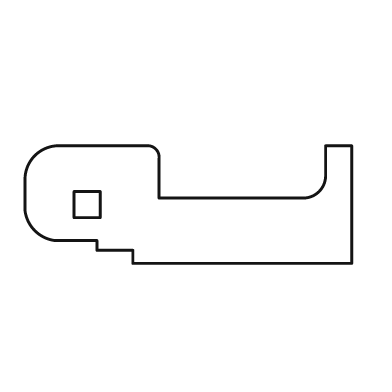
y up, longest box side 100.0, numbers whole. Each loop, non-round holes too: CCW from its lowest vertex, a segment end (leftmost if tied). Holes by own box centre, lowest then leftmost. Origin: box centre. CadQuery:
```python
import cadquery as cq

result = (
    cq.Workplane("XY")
    .moveTo(-17.0, -18.0)
    .lineTo(50.0, -18.0)
    .lineTo(50.0, 18.0)
    .lineTo(42.0, 18.0)
    .lineTo(42.0, 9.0)
    .threePointArc((40.0, 4.0), (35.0, 2.0))
    .lineTo(-9.0, 2.0)
    .lineTo(-9.0, 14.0)
    .threePointArc((-10.0, 17.0), (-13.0, 18.0))
    .lineTo(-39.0, 18.0)
    .threePointArc((-47.0, 15.0), (-50.0, 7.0))
    .lineTo(-50.0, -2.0)
    .threePointArc((-47.0, -8.0), (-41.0, -11.0))
    .lineTo(-28.0, -11.0)
    .lineTo(-28.0, -14.0)
    .lineTo(-17.0, -14.0)
    .close()
    .moveTo(-35.0, -4.0)
    .lineTo(-27.0, -4.0)
    .lineTo(-27.0, 4.0)
    .lineTo(-35.0, 4.0)
    .close()
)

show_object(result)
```